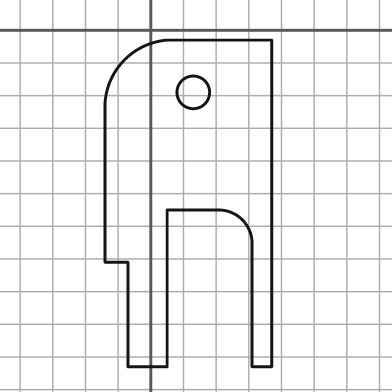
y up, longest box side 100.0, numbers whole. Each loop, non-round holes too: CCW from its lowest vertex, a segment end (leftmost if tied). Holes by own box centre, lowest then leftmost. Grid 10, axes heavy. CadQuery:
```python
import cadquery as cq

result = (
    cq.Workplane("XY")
    .moveTo(-7.0, -103.0)
    .lineTo(5.0, -103.0)
    .lineTo(5.0, -55.0)
    .lineTo(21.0, -55.0)
    .threePointArc((28.0, -58.0), (31.0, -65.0))
    .lineTo(31.0, -103.0)
    .lineTo(37.0, -103.0)
    .lineTo(37.0, -3.0)
    .lineTo(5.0, -3.0)
    .threePointArc((-8.0, -9.0), (-14.0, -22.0))
    .lineTo(-14.0, -71.0)
    .lineTo(-7.0, -71.0)
    .close()
    .moveTo(13.0, -19.0)
    .circle(5.0)
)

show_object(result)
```